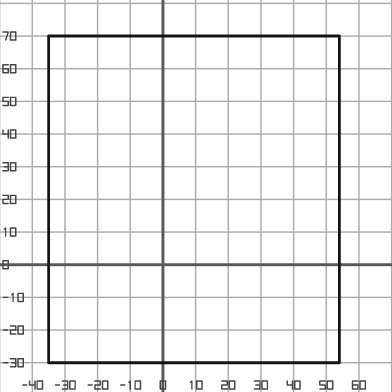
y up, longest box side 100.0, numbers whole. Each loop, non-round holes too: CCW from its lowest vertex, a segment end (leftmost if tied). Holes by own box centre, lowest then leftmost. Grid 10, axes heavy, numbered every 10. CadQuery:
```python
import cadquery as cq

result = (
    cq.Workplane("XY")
    .moveTo(-35.0, -30.0)
    .lineTo(54.0, -30.0)
    .lineTo(54.0, 70.0)
    .lineTo(-35.0, 70.0)
    .close()
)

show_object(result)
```